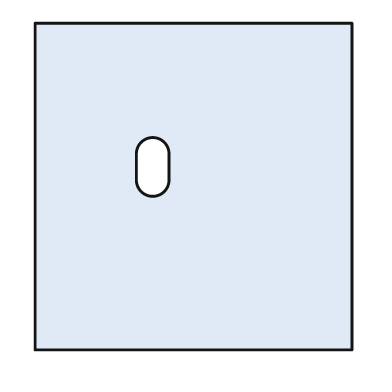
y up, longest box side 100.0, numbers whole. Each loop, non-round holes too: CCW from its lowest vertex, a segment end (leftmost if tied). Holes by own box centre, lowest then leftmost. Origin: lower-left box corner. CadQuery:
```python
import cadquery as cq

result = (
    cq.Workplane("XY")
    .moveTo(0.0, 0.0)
    .lineTo(97.0, 0.0)
    .lineTo(97.0, 100.0)
    .lineTo(0.0, 100.0)
    .close()
    .moveTo(31.0, 52.0)
    .threePointArc((36.0, 47.0), (41.0, 52.0))
    .lineTo(41.0, 60.0)
    .threePointArc((36.0, 65.0), (31.0, 60.0))
    .close()
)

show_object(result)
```